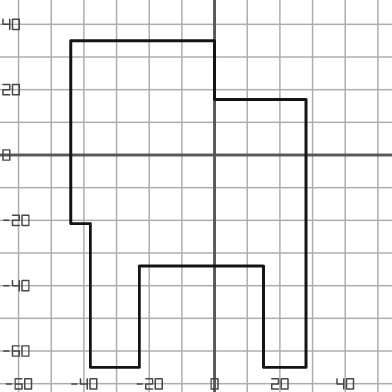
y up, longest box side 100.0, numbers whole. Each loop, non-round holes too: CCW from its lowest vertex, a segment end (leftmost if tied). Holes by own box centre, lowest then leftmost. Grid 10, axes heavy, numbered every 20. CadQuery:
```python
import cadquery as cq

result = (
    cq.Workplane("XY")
    .moveTo(-38.0, -65.0)
    .lineTo(-23.0, -65.0)
    .lineTo(-23.0, -34.0)
    .lineTo(15.0, -34.0)
    .lineTo(15.0, -65.0)
    .lineTo(28.0, -65.0)
    .lineTo(28.0, 17.0)
    .lineTo(0.0, 17.0)
    .lineTo(0.0, 35.0)
    .lineTo(-44.0, 35.0)
    .lineTo(-44.0, -21.0)
    .lineTo(-38.0, -21.0)
    .close()
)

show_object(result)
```